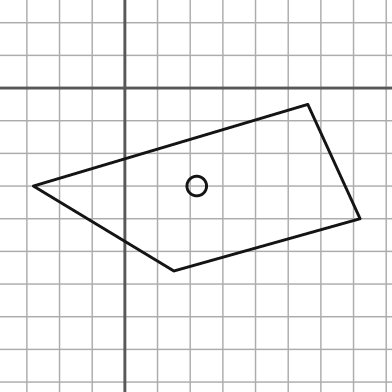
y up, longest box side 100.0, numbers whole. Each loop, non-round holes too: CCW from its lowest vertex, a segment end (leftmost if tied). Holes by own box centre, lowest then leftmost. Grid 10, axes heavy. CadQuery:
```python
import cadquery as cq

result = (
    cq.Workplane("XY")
    .moveTo(15.0, -56.0)
    .lineTo(72.0, -40.0)
    .lineTo(56.0, -5.0)
    .lineTo(-28.0, -30.0)
    .close()
    .moveTo(22.0, -30.0)
    .circle(3.0)
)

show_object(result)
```